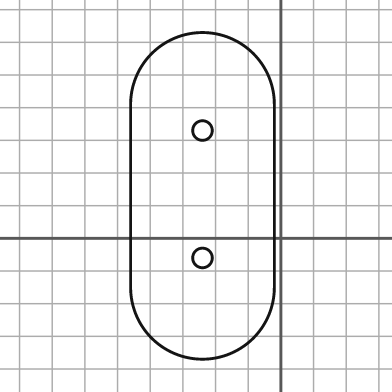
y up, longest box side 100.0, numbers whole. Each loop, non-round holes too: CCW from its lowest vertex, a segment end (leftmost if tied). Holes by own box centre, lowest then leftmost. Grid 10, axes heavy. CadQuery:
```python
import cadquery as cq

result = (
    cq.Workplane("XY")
    .moveTo(-46.0, -15.0)
    .threePointArc((-24.0, -37.0), (-2.0, -15.0))
    .lineTo(-2.0, 41.0)
    .threePointArc((-24.0, 63.0), (-46.0, 41.0))
    .close()
    .moveTo(-24.0, -6.0)
    .circle(3.0)
    .moveTo(-24.0, 33.0)
    .circle(3.0)
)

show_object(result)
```